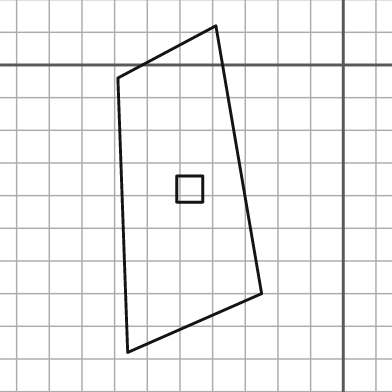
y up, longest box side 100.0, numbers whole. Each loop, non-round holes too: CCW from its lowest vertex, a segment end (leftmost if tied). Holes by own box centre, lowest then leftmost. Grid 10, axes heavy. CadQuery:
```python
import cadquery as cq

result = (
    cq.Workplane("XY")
    .moveTo(-66.0, -88.0)
    .lineTo(-25.0, -70.0)
    .lineTo(-39.0, 12.0)
    .lineTo(-69.0, -4.0)
    .close()
    .moveTo(-51.0, -42.0)
    .lineTo(-43.0, -42.0)
    .lineTo(-43.0, -34.0)
    .lineTo(-51.0, -34.0)
    .close()
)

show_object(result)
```